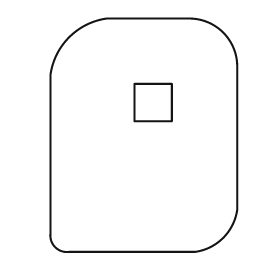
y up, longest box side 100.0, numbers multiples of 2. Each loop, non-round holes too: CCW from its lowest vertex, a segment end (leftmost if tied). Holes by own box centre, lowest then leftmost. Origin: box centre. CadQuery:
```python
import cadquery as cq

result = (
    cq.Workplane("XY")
    .moveTo(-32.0, -50.0)
    .lineTo(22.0, -50.0)
    .threePointArc((34.0, -44.0), (40.0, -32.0))
    .lineTo(40.0, 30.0)
    .threePointArc((34.0, 44.0), (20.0, 50.0))
    .lineTo(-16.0, 50.0)
    .threePointArc((-32.0, 42.0), (-40.0, 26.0))
    .lineTo(-40.0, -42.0)
    .threePointArc((-38.0, -48.0), (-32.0, -50.0))
    .close()
    .moveTo(-4.0, 6.0)
    .lineTo(12.0, 6.0)
    .lineTo(12.0, 22.0)
    .lineTo(-4.0, 22.0)
    .close()
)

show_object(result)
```